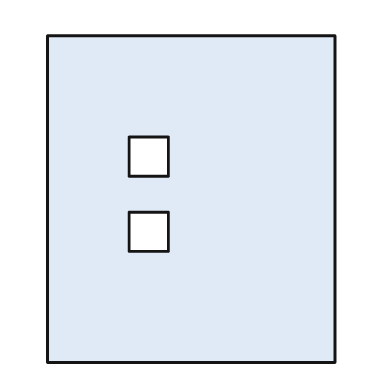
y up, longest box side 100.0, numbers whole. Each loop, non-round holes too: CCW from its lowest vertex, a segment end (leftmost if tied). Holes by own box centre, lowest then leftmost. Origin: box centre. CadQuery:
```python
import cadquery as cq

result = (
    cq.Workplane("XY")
    .moveTo(-44.0, -50.0)
    .lineTo(44.0, -50.0)
    .lineTo(44.0, 50.0)
    .lineTo(-44.0, 50.0)
    .close()
    .moveTo(-19.0, -16.0)
    .lineTo(-7.0, -16.0)
    .lineTo(-7.0, -4.0)
    .lineTo(-19.0, -4.0)
    .close()
    .moveTo(-19.0, 7.0)
    .lineTo(-7.0, 7.0)
    .lineTo(-7.0, 19.0)
    .lineTo(-19.0, 19.0)
    .close()
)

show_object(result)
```